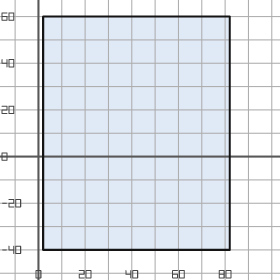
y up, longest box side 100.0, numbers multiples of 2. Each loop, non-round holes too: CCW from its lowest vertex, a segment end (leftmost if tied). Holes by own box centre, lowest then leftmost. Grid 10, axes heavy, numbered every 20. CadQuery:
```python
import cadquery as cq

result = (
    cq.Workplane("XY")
    .moveTo(2.0, -40.0)
    .lineTo(82.0, -40.0)
    .lineTo(82.0, 60.0)
    .lineTo(2.0, 60.0)
    .close()
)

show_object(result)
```